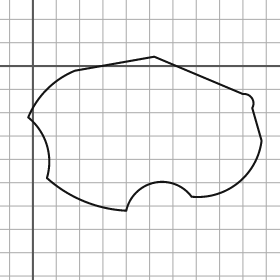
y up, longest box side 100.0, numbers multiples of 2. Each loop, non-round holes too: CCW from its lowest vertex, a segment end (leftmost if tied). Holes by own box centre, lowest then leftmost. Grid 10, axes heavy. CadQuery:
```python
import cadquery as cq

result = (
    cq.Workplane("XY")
    .moveTo(40.0, -62.0)
    .threePointArc((52.0, -50.0), (68.0, -56.0))
    .threePointArc((88.0, -50.0), (98.0, -32.0))
    .lineTo(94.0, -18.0)
    .threePointArc((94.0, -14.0), (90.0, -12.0))
    .lineTo(52.0, 4.0)
    .lineTo(18.0, -2.0)
    .threePointArc((6.0, -10.0), (-2.0, -22.0))
    .threePointArc((6.0, -34.0), (6.0, -48.0))
    .threePointArc((22.0, -58.0), (40.0, -62.0))
    .close()
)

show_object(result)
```